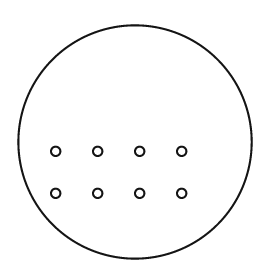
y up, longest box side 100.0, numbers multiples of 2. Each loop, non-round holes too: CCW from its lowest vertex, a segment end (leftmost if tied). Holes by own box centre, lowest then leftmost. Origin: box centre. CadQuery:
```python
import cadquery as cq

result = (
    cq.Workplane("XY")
    .moveTo(0.0, 0.0)
    .circle(50.0)
    .moveTo(-34.0, -22.0)
    .circle(2.0)
    .moveTo(-16.0, -22.0)
    .circle(2.0)
    .moveTo(2.0, -22.0)
    .circle(2.0)
    .moveTo(20.0, -22.0)
    .circle(2.0)
    .moveTo(-34.0, -4.0)
    .circle(2.0)
    .moveTo(-16.0, -4.0)
    .circle(2.0)
    .moveTo(2.0, -4.0)
    .circle(2.0)
    .moveTo(20.0, -4.0)
    .circle(2.0)
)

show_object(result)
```